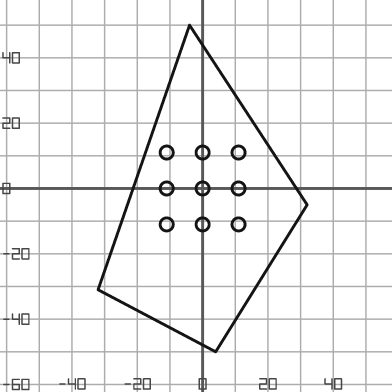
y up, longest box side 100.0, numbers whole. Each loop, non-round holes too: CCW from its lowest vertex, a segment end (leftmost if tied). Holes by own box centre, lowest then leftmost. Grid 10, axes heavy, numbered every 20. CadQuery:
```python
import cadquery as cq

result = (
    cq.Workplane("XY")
    .moveTo(4.0, -50.0)
    .lineTo(32.0, -5.0)
    .lineTo(-4.0, 50.0)
    .lineTo(-32.0, -31.0)
    .close()
    .moveTo(-11.0, -11.0)
    .circle(2.0)
    .moveTo(0.0, -11.0)
    .circle(2.0)
    .moveTo(11.0, -11.0)
    .circle(2.0)
    .moveTo(-11.0, 0.0)
    .circle(2.0)
    .moveTo(0.0, 0.0)
    .circle(2.0)
    .moveTo(11.0, 0.0)
    .circle(2.0)
    .moveTo(-11.0, 11.0)
    .circle(2.0)
    .moveTo(0.0, 11.0)
    .circle(2.0)
    .moveTo(11.0, 11.0)
    .circle(2.0)
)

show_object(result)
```